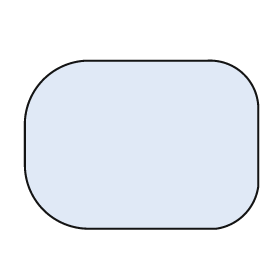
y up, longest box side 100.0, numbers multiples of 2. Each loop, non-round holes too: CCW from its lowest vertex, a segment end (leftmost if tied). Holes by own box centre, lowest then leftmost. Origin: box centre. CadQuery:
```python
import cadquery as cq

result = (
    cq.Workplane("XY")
    .moveTo(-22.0, -36.0)
    .lineTo(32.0, -36.0)
    .threePointArc((44.0, -30.0), (50.0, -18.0))
    .lineTo(50.0, 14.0)
    .threePointArc((44.0, 30.0), (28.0, 36.0))
    .lineTo(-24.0, 36.0)
    .threePointArc((-42.0, 28.0), (-50.0, 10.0))
    .lineTo(-50.0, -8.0)
    .threePointArc((-42.0, -28.0), (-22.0, -36.0))
    .close()
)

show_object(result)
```